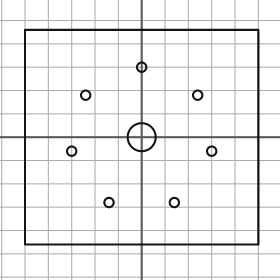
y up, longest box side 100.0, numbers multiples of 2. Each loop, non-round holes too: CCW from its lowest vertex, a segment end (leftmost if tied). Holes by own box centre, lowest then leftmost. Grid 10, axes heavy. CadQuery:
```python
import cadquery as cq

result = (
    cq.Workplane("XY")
    .moveTo(-50.0, -46.0)
    .lineTo(50.0, -46.0)
    .lineTo(50.0, 46.0)
    .lineTo(-50.0, 46.0)
    .close()
    .moveTo(-14.0, -28.0)
    .circle(2.0)
    .moveTo(14.0, -28.0)
    .circle(2.0)
    .moveTo(-30.0, -6.0)
    .circle(2.0)
    .moveTo(30.0, -6.0)
    .circle(2.0)
    .moveTo(0.0, 0.0)
    .circle(6.0)
    .moveTo(-24.0, 18.0)
    .circle(2.0)
    .moveTo(24.0, 18.0)
    .circle(2.0)
    .moveTo(0.0, 30.0)
    .circle(2.0)
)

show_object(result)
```